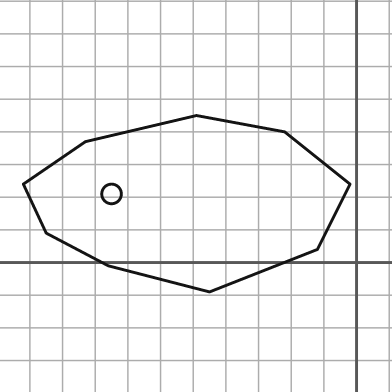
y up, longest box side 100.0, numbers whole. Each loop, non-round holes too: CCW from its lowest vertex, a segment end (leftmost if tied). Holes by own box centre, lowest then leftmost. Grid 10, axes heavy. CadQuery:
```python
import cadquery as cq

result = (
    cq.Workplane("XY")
    .moveTo(-45.0, -9.0)
    .lineTo(-12.0, 4.0)
    .lineTo(-2.0, 24.0)
    .lineTo(-22.0, 40.0)
    .lineTo(-49.0, 45.0)
    .lineTo(-83.0, 37.0)
    .lineTo(-102.0, 24.0)
    .lineTo(-95.0, 9.0)
    .lineTo(-76.0, -1.0)
    .close()
    .moveTo(-75.0, 21.0)
    .circle(3.0)
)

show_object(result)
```